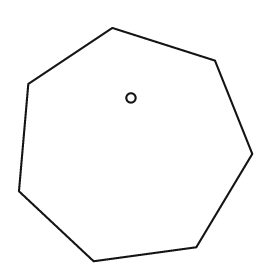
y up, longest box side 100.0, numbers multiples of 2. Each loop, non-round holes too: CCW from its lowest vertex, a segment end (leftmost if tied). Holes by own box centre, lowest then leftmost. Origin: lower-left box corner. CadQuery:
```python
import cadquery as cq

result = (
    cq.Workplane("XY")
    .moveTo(32.0, 0.0)
    .lineTo(76.0, 6.0)
    .lineTo(100.0, 46.0)
    .lineTo(84.0, 86.0)
    .lineTo(40.0, 100.0)
    .lineTo(4.0, 76.0)
    .lineTo(0.0, 30.0)
    .close()
    .moveTo(48.0, 70.0)
    .circle(2.0)
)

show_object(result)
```